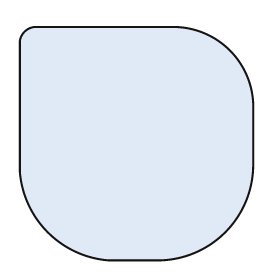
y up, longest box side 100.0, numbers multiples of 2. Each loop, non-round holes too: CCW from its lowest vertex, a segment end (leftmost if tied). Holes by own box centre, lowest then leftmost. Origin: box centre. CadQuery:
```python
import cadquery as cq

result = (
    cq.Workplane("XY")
    .moveTo(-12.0, -50.0)
    .lineTo(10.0, -50.0)
    .threePointArc((38.0, -38.0), (50.0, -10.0))
    .lineTo(50.0, 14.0)
    .threePointArc((40.0, 40.0), (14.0, 50.0))
    .lineTo(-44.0, 50.0)
    .threePointArc((-48.0, 48.0), (-50.0, 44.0))
    .lineTo(-50.0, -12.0)
    .threePointArc((-38.0, -38.0), (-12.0, -50.0))
    .close()
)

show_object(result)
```